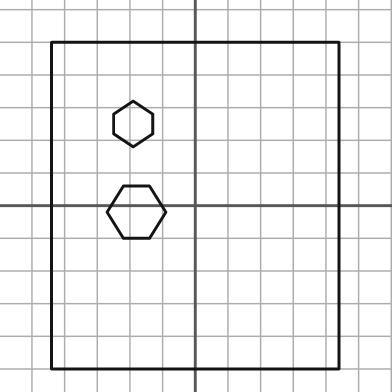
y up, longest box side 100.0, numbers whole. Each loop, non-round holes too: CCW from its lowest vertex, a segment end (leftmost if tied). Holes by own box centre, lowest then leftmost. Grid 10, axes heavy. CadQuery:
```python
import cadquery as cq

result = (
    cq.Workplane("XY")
    .moveTo(-44.0, -50.0)
    .lineTo(44.0, -50.0)
    .lineTo(44.0, 50.0)
    .lineTo(-44.0, 50.0)
    .close()
    .moveTo(-22.0, -10.0)
    .lineTo(-14.0, -10.0)
    .lineTo(-9.0, -2.0)
    .lineTo(-14.0, 6.0)
    .lineTo(-22.0, 6.0)
    .lineTo(-27.0, -2.0)
    .close()
    .moveTo(-19.0, 18.0)
    .lineTo(-13.0, 22.0)
    .lineTo(-13.0, 28.0)
    .lineTo(-19.0, 32.0)
    .lineTo(-25.0, 28.0)
    .lineTo(-25.0, 22.0)
    .close()
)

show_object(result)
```